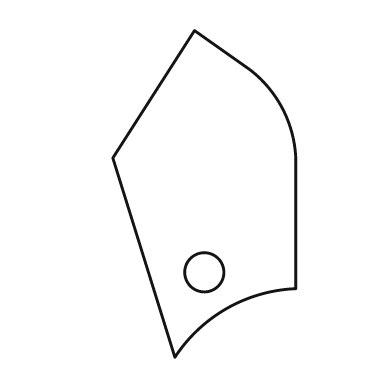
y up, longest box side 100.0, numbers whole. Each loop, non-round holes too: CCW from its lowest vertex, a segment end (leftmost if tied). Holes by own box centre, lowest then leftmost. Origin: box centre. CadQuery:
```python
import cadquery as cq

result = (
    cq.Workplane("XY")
    .moveTo(-9.0, -50.0)
    .threePointArc((7.0, -35.0), (28.0, -29.0))
    .lineTo(28.0, 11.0)
    .threePointArc((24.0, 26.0), (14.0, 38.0))
    .lineTo(-3.0, 50.0)
    .lineTo(-28.0, 11.0)
    .close()
    .moveTo(0.0, -24.0)
    .circle(6.0)
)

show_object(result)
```